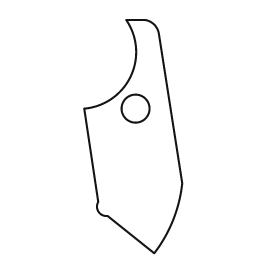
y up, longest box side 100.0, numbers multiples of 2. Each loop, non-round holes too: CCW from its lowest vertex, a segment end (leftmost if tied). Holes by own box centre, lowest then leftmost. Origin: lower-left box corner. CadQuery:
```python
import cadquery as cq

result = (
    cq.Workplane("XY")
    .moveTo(30.0, 0.0)
    .threePointArc((38.0, 14.0), (42.0, 30.0))
    .lineTo(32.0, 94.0)
    .threePointArc((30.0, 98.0), (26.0, 100.0))
    .lineTo(18.0, 100.0)
    .threePointArc((20.0, 76.0), (0.0, 62.0))
    .lineTo(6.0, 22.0)
    .threePointArc((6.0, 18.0), (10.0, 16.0))
    .close()
    .moveTo(22.0, 62.0)
    .circle(6.0)
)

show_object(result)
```